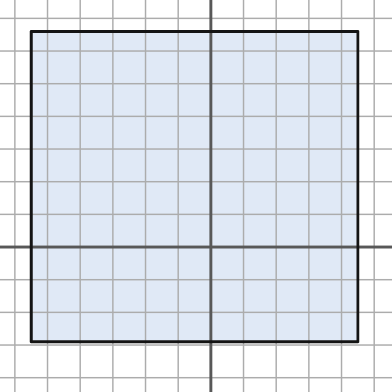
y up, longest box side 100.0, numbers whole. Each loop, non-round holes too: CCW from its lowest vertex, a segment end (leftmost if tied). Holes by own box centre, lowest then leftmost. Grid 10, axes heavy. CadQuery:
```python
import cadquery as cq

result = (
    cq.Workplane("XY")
    .moveTo(-55.0, -29.0)
    .lineTo(45.0, -29.0)
    .lineTo(45.0, 66.0)
    .lineTo(-55.0, 66.0)
    .close()
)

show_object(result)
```